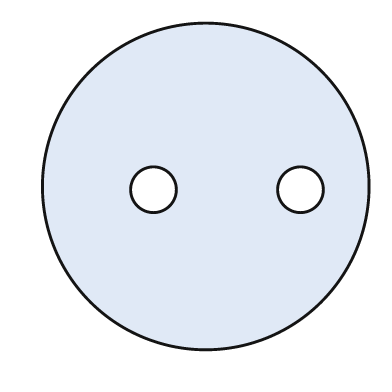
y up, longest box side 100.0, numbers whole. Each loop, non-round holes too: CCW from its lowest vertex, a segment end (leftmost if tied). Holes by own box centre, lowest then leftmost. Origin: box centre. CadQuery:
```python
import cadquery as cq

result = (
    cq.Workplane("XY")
    .moveTo(0.0, 0.0)
    .circle(50.0)
    .moveTo(-16.0, -1.0)
    .circle(7.0)
    .moveTo(29.0, -1.0)
    .circle(7.0)
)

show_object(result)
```